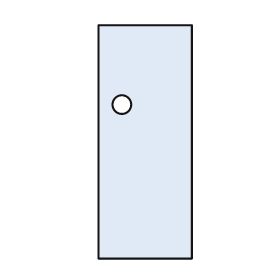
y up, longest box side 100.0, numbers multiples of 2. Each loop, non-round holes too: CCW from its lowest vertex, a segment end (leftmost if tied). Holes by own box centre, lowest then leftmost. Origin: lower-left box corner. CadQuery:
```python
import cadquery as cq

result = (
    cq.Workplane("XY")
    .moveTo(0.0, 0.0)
    .lineTo(40.0, 0.0)
    .lineTo(40.0, 100.0)
    .lineTo(0.0, 100.0)
    .close()
    .moveTo(10.0, 66.0)
    .circle(4.0)
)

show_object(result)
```